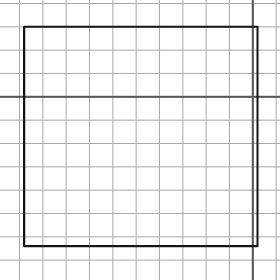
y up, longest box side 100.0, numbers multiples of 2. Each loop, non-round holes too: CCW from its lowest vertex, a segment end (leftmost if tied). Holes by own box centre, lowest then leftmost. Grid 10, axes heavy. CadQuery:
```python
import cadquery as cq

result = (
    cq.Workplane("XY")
    .moveTo(-98.0, -64.0)
    .lineTo(2.0, -64.0)
    .lineTo(2.0, 30.0)
    .lineTo(-98.0, 30.0)
    .close()
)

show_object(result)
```